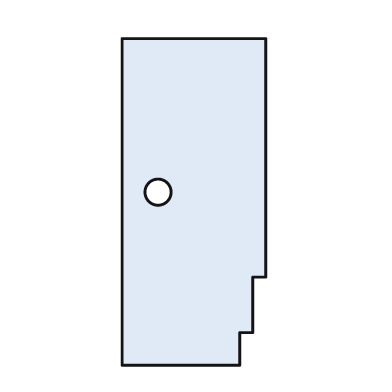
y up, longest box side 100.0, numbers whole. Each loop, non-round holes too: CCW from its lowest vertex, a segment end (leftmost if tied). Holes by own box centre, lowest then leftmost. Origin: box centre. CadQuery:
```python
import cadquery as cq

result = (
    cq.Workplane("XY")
    .moveTo(-22.0, -50.0)
    .lineTo(14.0, -50.0)
    .lineTo(14.0, -40.0)
    .lineTo(18.0, -40.0)
    .lineTo(18.0, -23.0)
    .lineTo(22.0, -23.0)
    .lineTo(22.0, 50.0)
    .lineTo(-22.0, 50.0)
    .close()
    .moveTo(-11.0, 3.0)
    .circle(4.0)
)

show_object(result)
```